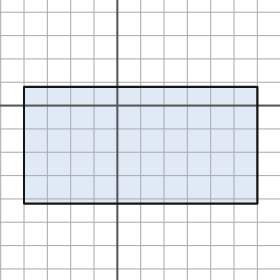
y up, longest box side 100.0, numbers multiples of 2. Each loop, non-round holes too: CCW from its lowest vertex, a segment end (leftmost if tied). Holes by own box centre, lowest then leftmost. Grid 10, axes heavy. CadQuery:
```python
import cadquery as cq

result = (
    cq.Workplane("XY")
    .moveTo(-40.0, -42.0)
    .lineTo(60.0, -42.0)
    .lineTo(60.0, 8.0)
    .lineTo(-40.0, 8.0)
    .close()
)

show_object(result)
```